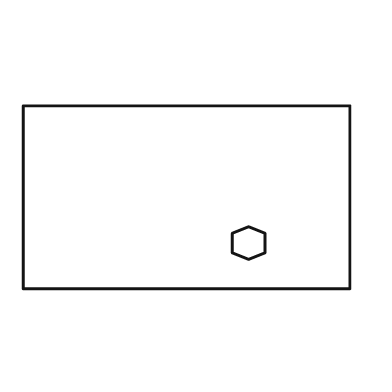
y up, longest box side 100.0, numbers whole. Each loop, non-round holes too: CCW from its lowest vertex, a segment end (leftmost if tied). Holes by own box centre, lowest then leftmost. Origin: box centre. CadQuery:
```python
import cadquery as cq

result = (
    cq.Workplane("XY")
    .moveTo(-50.0, -28.0)
    .lineTo(50.0, -28.0)
    .lineTo(50.0, 28.0)
    .lineTo(-50.0, 28.0)
    .close()
    .moveTo(19.0, -19.0)
    .lineTo(24.0, -17.0)
    .lineTo(24.0, -11.0)
    .lineTo(19.0, -9.0)
    .lineTo(14.0, -11.0)
    .lineTo(14.0, -17.0)
    .close()
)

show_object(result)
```